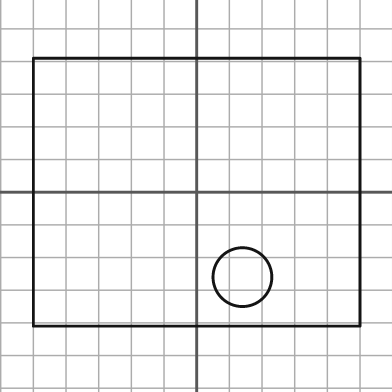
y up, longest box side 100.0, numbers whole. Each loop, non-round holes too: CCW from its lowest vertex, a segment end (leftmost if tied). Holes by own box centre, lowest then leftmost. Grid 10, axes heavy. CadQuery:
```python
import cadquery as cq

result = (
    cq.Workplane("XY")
    .moveTo(-50.0, -41.0)
    .lineTo(50.0, -41.0)
    .lineTo(50.0, 41.0)
    .lineTo(-50.0, 41.0)
    .close()
    .moveTo(14.0, -26.0)
    .circle(9.0)
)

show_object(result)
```